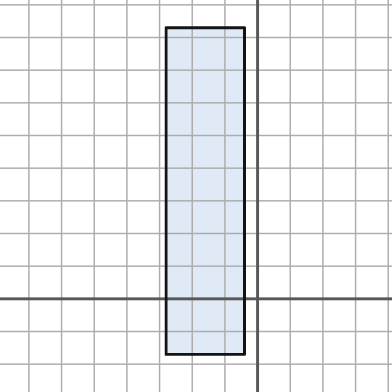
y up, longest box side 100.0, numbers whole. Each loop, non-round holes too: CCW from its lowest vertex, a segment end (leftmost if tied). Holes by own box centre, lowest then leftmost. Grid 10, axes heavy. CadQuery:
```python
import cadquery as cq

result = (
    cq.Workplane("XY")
    .moveTo(-28.0, -17.0)
    .lineTo(-4.0, -17.0)
    .lineTo(-4.0, 83.0)
    .lineTo(-28.0, 83.0)
    .close()
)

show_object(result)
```